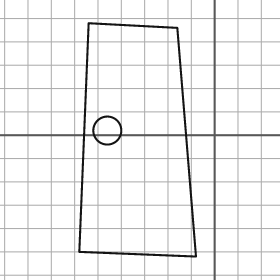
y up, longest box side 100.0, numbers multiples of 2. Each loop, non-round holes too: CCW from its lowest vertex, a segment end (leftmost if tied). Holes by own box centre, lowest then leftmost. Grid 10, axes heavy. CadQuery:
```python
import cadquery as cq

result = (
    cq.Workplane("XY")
    .moveTo(-8.0, -52.0)
    .lineTo(-16.0, 46.0)
    .lineTo(-54.0, 48.0)
    .lineTo(-58.0, -50.0)
    .close()
    .moveTo(-46.0, 2.0)
    .circle(6.0)
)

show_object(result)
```